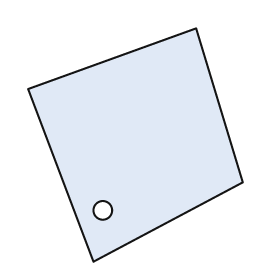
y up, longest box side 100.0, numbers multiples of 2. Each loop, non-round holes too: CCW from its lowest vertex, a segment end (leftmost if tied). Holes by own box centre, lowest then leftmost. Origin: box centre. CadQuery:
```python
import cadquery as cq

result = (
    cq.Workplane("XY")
    .moveTo(-18.0, -50.0)
    .lineTo(46.0, -16.0)
    .lineTo(26.0, 50.0)
    .lineTo(-46.0, 24.0)
    .close()
    .moveTo(-14.0, -28.0)
    .circle(4.0)
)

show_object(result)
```